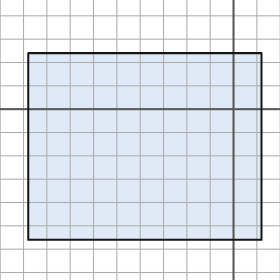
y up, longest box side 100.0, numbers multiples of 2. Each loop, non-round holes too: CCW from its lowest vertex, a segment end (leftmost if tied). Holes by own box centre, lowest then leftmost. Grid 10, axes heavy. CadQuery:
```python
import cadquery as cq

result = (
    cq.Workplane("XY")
    .moveTo(-88.0, -56.0)
    .lineTo(12.0, -56.0)
    .lineTo(12.0, 24.0)
    .lineTo(-88.0, 24.0)
    .close()
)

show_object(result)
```